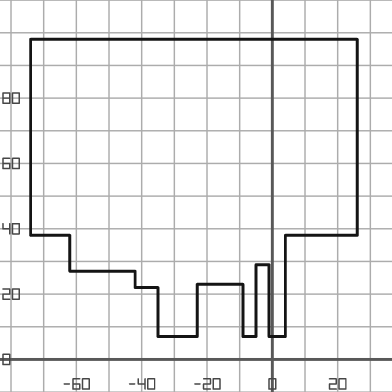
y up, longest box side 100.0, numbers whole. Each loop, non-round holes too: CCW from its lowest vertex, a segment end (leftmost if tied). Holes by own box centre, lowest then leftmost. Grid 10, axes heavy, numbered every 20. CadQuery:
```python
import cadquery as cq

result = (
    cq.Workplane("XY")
    .moveTo(-35.0, 7.0)
    .lineTo(-23.0, 7.0)
    .lineTo(-23.0, 23.0)
    .lineTo(-9.0, 23.0)
    .lineTo(-9.0, 7.0)
    .lineTo(-5.0, 7.0)
    .lineTo(-5.0, 29.0)
    .lineTo(-1.0, 29.0)
    .lineTo(-1.0, 7.0)
    .lineTo(4.0, 7.0)
    .lineTo(4.0, 38.0)
    .lineTo(26.0, 38.0)
    .lineTo(26.0, 98.0)
    .lineTo(-74.0, 98.0)
    .lineTo(-74.0, 38.0)
    .lineTo(-62.0, 38.0)
    .lineTo(-62.0, 27.0)
    .lineTo(-42.0, 27.0)
    .lineTo(-42.0, 22.0)
    .lineTo(-35.0, 22.0)
    .close()
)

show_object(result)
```